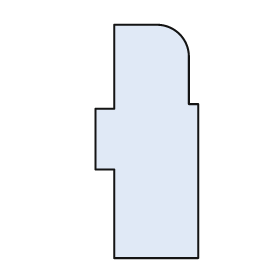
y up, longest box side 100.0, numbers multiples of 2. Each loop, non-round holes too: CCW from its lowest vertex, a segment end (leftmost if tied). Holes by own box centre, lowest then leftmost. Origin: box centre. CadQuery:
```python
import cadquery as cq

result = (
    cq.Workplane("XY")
    .moveTo(-14.0, -50.0)
    .lineTo(22.0, -50.0)
    .lineTo(22.0, 16.0)
    .lineTo(18.0, 16.0)
    .lineTo(18.0, 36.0)
    .threePointArc((14.0, 46.0), (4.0, 50.0))
    .lineTo(-14.0, 50.0)
    .lineTo(-14.0, 14.0)
    .lineTo(-22.0, 14.0)
    .lineTo(-22.0, -12.0)
    .lineTo(-14.0, -12.0)
    .close()
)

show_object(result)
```